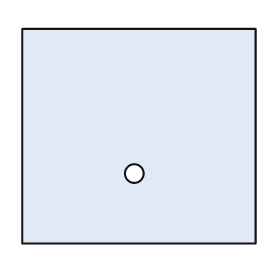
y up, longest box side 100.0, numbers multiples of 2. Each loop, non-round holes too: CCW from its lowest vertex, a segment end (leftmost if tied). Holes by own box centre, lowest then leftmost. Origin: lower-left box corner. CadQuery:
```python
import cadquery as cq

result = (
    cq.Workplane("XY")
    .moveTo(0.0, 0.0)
    .lineTo(100.0, 0.0)
    .lineTo(100.0, 92.0)
    .lineTo(0.0, 92.0)
    .close()
    .moveTo(48.0, 30.0)
    .circle(4.0)
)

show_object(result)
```